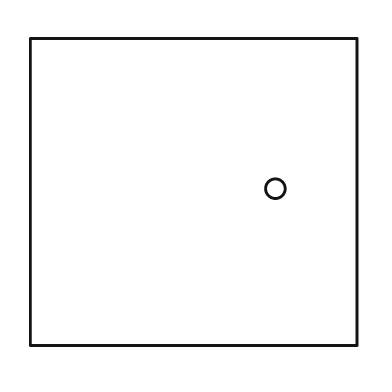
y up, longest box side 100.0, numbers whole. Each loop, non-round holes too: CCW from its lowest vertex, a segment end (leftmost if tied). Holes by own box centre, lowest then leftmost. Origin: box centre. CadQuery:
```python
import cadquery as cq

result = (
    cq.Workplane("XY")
    .moveTo(-50.0, -47.0)
    .lineTo(50.0, -47.0)
    .lineTo(50.0, 47.0)
    .lineTo(-50.0, 47.0)
    .close()
    .moveTo(25.0, 1.0)
    .circle(3.0)
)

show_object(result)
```